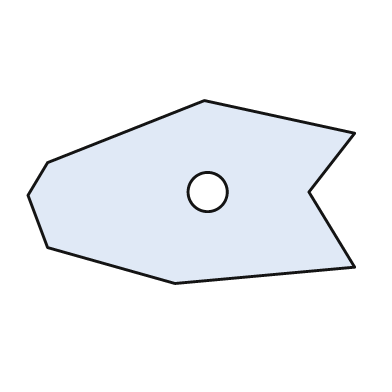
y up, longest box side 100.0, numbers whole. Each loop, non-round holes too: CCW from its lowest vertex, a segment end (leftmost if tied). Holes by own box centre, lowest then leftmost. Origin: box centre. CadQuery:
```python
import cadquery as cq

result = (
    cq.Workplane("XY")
    .moveTo(-5.0, -28.0)
    .lineTo(50.0, -23.0)
    .lineTo(36.0, 0.0)
    .lineTo(50.0, 18.0)
    .lineTo(4.0, 28.0)
    .lineTo(-44.0, 9.0)
    .lineTo(-50.0, -1.0)
    .lineTo(-44.0, -17.0)
    .close()
    .moveTo(5.0, 0.0)
    .circle(6.0)
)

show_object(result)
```